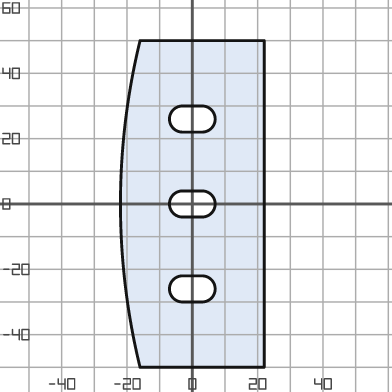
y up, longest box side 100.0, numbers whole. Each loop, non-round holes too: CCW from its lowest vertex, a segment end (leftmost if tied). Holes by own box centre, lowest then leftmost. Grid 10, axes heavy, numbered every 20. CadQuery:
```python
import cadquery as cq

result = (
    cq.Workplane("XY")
    .moveTo(-16.0, -50.0)
    .lineTo(22.0, -50.0)
    .lineTo(22.0, 50.0)
    .lineTo(-16.0, 50.0)
    .threePointArc((-22.0, 0.0), (-16.0, -50.0))
    .close()
    .moveTo(-3.0, -30.0)
    .lineTo(3.0, -30.0)
    .threePointArc((7.0, -26.0), (3.0, -22.0))
    .lineTo(-3.0, -22.0)
    .threePointArc((-7.0, -26.0), (-3.0, -30.0))
    .close()
    .moveTo(-3.0, -4.0)
    .lineTo(3.0, -4.0)
    .threePointArc((7.0, 0.0), (3.0, 4.0))
    .lineTo(-3.0, 4.0)
    .threePointArc((-7.0, 0.0), (-3.0, -4.0))
    .close()
    .moveTo(-3.0, 22.0)
    .lineTo(3.0, 22.0)
    .threePointArc((7.0, 26.0), (3.0, 30.0))
    .lineTo(-3.0, 30.0)
    .threePointArc((-7.0, 26.0), (-3.0, 22.0))
    .close()
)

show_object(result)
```